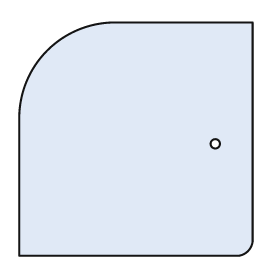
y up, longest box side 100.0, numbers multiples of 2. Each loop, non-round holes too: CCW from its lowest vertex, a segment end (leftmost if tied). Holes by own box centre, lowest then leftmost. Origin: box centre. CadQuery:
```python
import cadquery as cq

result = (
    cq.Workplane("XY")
    .moveTo(-50.0, -50.0)
    .lineTo(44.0, -50.0)
    .threePointArc((48.0, -48.0), (50.0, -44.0))
    .lineTo(50.0, 50.0)
    .lineTo(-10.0, 50.0)
    .threePointArc((-38.0, 38.0), (-50.0, 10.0))
    .close()
    .moveTo(34.0, -2.0)
    .circle(2.0)
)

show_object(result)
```